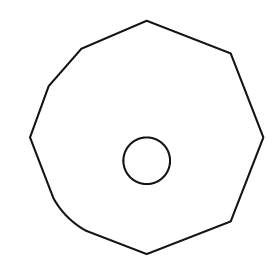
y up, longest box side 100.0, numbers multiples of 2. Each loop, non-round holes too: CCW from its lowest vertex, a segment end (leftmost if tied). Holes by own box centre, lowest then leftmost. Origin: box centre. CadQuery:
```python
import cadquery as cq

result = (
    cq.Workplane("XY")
    .moveTo(0.0, -50.0)
    .lineTo(36.0, -36.0)
    .lineTo(50.0, 0.0)
    .lineTo(36.0, 36.0)
    .lineTo(0.0, 50.0)
    .lineTo(-28.0, 38.0)
    .lineTo(-42.0, 22.0)
    .lineTo(-50.0, 0.0)
    .lineTo(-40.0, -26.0)
    .threePointArc((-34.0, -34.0), (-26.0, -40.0))
    .close()
    .moveTo(0.0, -10.0)
    .circle(10.0)
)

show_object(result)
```